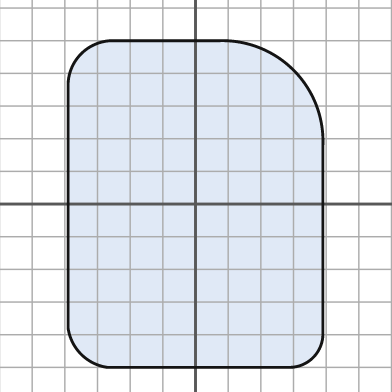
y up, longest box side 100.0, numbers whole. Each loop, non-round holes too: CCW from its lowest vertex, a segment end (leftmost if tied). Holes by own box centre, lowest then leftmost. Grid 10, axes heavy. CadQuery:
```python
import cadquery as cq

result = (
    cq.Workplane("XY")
    .moveTo(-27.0, -50.0)
    .lineTo(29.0, -50.0)
    .threePointArc((36.0, -47.0), (39.0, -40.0))
    .lineTo(39.0, 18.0)
    .threePointArc((30.0, 41.0), (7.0, 50.0))
    .lineTo(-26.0, 50.0)
    .threePointArc((-35.0, 46.0), (-39.0, 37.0))
    .lineTo(-39.0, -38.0)
    .threePointArc((-35.0, -46.0), (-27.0, -50.0))
    .close()
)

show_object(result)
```